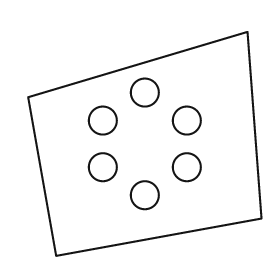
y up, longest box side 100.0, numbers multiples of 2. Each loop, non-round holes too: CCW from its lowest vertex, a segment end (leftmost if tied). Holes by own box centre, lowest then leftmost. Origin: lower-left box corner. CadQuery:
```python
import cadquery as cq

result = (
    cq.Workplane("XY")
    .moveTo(12.0, 0.0)
    .lineTo(100.0, 16.0)
    .lineTo(94.0, 96.0)
    .lineTo(0.0, 68.0)
    .close()
    .moveTo(50.0, 26.0)
    .circle(6.0)
    .moveTo(32.0, 38.0)
    .circle(6.0)
    .moveTo(68.0, 38.0)
    .circle(6.0)
    .moveTo(32.0, 58.0)
    .circle(6.0)
    .moveTo(68.0, 58.0)
    .circle(6.0)
    .moveTo(50.0, 70.0)
    .circle(6.0)
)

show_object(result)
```